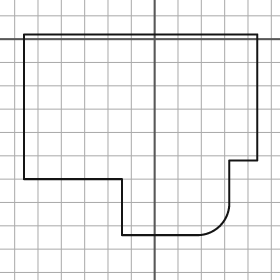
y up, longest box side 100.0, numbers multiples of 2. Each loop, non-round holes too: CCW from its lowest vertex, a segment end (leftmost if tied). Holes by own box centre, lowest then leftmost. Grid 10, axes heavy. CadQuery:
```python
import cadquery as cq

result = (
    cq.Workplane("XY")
    .moveTo(-14.0, -84.0)
    .lineTo(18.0, -84.0)
    .threePointArc((28.0, -80.0), (32.0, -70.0))
    .lineTo(32.0, -52.0)
    .lineTo(44.0, -52.0)
    .lineTo(44.0, 2.0)
    .lineTo(-56.0, 2.0)
    .lineTo(-56.0, -60.0)
    .lineTo(-14.0, -60.0)
    .close()
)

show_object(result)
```